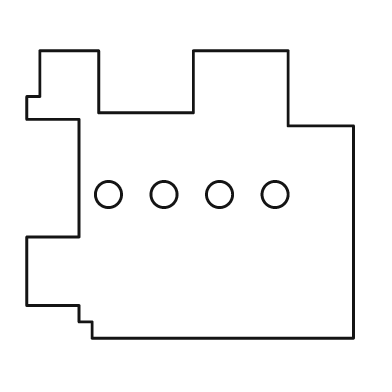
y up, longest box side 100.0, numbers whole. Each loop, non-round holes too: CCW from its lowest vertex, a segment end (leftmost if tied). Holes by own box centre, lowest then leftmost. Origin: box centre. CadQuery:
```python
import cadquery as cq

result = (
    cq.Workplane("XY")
    .moveTo(-30.0, -44.0)
    .lineTo(50.0, -44.0)
    .lineTo(50.0, 21.0)
    .lineTo(30.0, 21.0)
    .lineTo(30.0, 44.0)
    .lineTo(1.0, 44.0)
    .lineTo(1.0, 25.0)
    .lineTo(-28.0, 25.0)
    .lineTo(-28.0, 44.0)
    .lineTo(-46.0, 44.0)
    .lineTo(-46.0, 30.0)
    .lineTo(-50.0, 30.0)
    .lineTo(-50.0, 23.0)
    .lineTo(-34.0, 23.0)
    .lineTo(-34.0, -13.0)
    .lineTo(-50.0, -13.0)
    .lineTo(-50.0, -34.0)
    .lineTo(-34.0, -34.0)
    .lineTo(-34.0, -39.0)
    .lineTo(-30.0, -39.0)
    .close()
    .moveTo(-25.0, 0.0)
    .circle(4.0)
    .moveTo(-8.0, 0.0)
    .circle(4.0)
    .moveTo(9.0, 0.0)
    .circle(4.0)
    .moveTo(26.0, 0.0)
    .circle(4.0)
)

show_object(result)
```